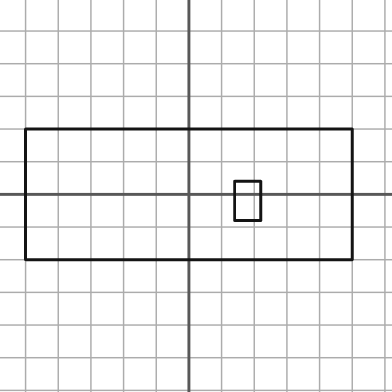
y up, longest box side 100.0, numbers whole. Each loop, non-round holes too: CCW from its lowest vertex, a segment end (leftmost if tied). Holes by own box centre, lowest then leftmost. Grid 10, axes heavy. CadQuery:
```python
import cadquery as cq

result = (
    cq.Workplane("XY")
    .moveTo(-50.0, -20.0)
    .lineTo(50.0, -20.0)
    .lineTo(50.0, 20.0)
    .lineTo(-50.0, 20.0)
    .close()
    .moveTo(14.0, -8.0)
    .lineTo(22.0, -8.0)
    .lineTo(22.0, 4.0)
    .lineTo(14.0, 4.0)
    .close()
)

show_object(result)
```